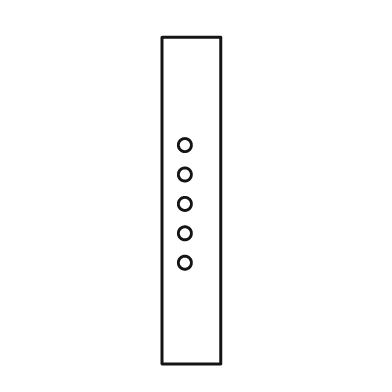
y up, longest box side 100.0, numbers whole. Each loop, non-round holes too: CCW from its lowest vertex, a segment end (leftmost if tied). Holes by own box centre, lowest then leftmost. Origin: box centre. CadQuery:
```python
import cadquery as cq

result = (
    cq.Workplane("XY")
    .moveTo(-9.0, -50.0)
    .lineTo(9.0, -50.0)
    .lineTo(9.0, 50.0)
    .lineTo(-9.0, 50.0)
    .close()
    .moveTo(-2.0, -19.0)
    .circle(2.0)
    .moveTo(-2.0, -10.0)
    .circle(2.0)
    .moveTo(-2.0, -1.0)
    .circle(2.0)
    .moveTo(-2.0, 8.0)
    .circle(2.0)
    .moveTo(-2.0, 17.0)
    .circle(2.0)
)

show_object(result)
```